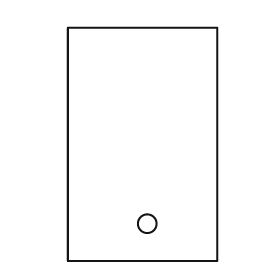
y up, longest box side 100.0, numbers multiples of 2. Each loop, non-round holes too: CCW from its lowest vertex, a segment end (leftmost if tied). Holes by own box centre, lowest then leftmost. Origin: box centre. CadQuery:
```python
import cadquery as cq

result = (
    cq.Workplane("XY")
    .moveTo(-32.0, -50.0)
    .lineTo(32.0, -50.0)
    .lineTo(32.0, 50.0)
    .lineTo(-32.0, 50.0)
    .close()
    .moveTo(2.0, -34.0)
    .circle(4.0)
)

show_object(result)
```